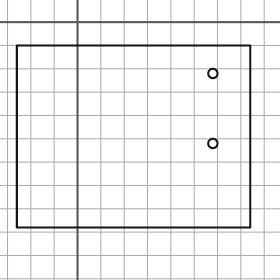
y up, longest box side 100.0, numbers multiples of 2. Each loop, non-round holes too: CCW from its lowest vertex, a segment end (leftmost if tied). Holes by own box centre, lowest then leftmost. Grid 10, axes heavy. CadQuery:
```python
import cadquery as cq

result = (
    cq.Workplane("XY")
    .moveTo(-26.0, -88.0)
    .lineTo(74.0, -88.0)
    .lineTo(74.0, -10.0)
    .lineTo(-26.0, -10.0)
    .close()
    .moveTo(58.0, -52.0)
    .circle(2.0)
    .moveTo(58.0, -22.0)
    .circle(2.0)
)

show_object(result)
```